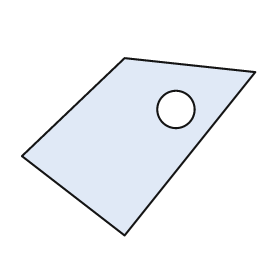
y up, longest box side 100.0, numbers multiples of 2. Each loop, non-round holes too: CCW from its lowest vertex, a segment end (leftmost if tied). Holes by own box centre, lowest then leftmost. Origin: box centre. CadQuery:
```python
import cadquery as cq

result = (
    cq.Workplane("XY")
    .moveTo(-6.0, -38.0)
    .lineTo(50.0, 32.0)
    .lineTo(-6.0, 38.0)
    .lineTo(-50.0, -4.0)
    .close()
    .moveTo(16.0, 16.0)
    .circle(8.0)
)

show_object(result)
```